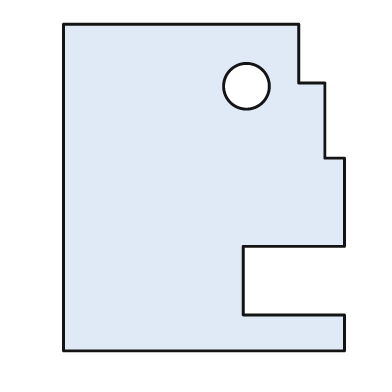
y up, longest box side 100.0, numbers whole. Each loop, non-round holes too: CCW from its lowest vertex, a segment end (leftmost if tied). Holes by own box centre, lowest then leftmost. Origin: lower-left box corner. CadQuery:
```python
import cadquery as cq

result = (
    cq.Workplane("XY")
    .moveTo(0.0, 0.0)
    .lineTo(86.0, 0.0)
    .lineTo(86.0, 11.0)
    .lineTo(55.0, 11.0)
    .lineTo(55.0, 32.0)
    .lineTo(86.0, 32.0)
    .lineTo(86.0, 59.0)
    .lineTo(80.0, 59.0)
    .lineTo(80.0, 82.0)
    .lineTo(72.0, 82.0)
    .lineTo(72.0, 100.0)
    .lineTo(0.0, 100.0)
    .close()
    .moveTo(56.0, 81.0)
    .circle(7.0)
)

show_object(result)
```